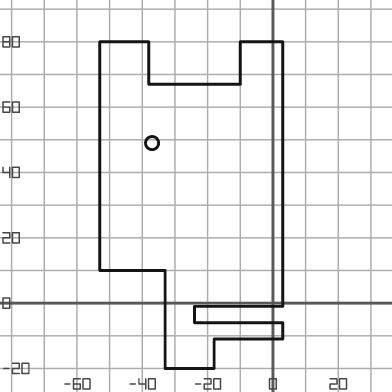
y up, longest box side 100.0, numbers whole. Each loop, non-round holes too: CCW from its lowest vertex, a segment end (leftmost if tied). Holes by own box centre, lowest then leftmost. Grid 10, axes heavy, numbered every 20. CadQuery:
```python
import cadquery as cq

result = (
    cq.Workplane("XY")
    .moveTo(-33.0, -20.0)
    .lineTo(-18.0, -20.0)
    .lineTo(-18.0, -11.0)
    .lineTo(3.0, -11.0)
    .lineTo(3.0, -6.0)
    .lineTo(-24.0, -6.0)
    .lineTo(-24.0, -1.0)
    .lineTo(3.0, -1.0)
    .lineTo(3.0, 80.0)
    .lineTo(-10.0, 80.0)
    .lineTo(-10.0, 67.0)
    .lineTo(-38.0, 67.0)
    .lineTo(-38.0, 80.0)
    .lineTo(-53.0, 80.0)
    .lineTo(-53.0, 10.0)
    .lineTo(-33.0, 10.0)
    .close()
    .moveTo(-37.0, 49.0)
    .circle(2.0)
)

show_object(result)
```